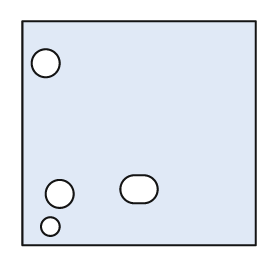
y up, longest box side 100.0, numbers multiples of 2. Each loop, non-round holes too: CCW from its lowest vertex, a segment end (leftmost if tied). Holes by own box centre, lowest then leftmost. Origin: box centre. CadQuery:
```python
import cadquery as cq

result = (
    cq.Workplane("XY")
    .moveTo(-50.0, -48.0)
    .lineTo(50.0, -48.0)
    .lineTo(50.0, 48.0)
    .lineTo(-50.0, 48.0)
    .close()
    .moveTo(-38.0, -40.0)
    .circle(4.0)
    .moveTo(-34.0, -26.0)
    .circle(6.0)
    .moveTo(-2.0, -30.0)
    .lineTo(2.0, -30.0)
    .threePointArc((8.0, -24.0), (2.0, -18.0))
    .lineTo(-2.0, -18.0)
    .threePointArc((-8.0, -24.0), (-2.0, -30.0))
    .close()
    .moveTo(-40.0, 30.0)
    .circle(6.0)
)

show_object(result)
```